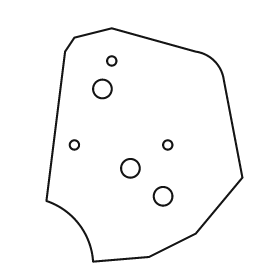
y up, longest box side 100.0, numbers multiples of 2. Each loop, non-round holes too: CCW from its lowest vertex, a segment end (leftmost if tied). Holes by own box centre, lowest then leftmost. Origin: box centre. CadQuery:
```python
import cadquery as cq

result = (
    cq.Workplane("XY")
    .moveTo(-22.0, -50.0)
    .lineTo(2.0, -48.0)
    .lineTo(22.0, -38.0)
    .lineTo(42.0, -14.0)
    .lineTo(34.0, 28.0)
    .threePointArc((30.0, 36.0), (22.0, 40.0))
    .lineTo(-14.0, 50.0)
    .lineTo(-30.0, 46.0)
    .lineTo(-34.0, 40.0)
    .lineTo(-42.0, -24.0)
    .threePointArc((-28.0, -34.0), (-22.0, -50.0))
    .close()
    .moveTo(8.0, -22.0)
    .circle(4.0)
    .moveTo(-6.0, -10.0)
    .circle(4.0)
    .moveTo(-30.0, 0.0)
    .circle(2.0)
    .moveTo(10.0, 0.0)
    .circle(2.0)
    .moveTo(-18.0, 24.0)
    .circle(4.0)
    .moveTo(-14.0, 36.0)
    .circle(2.0)
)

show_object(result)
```